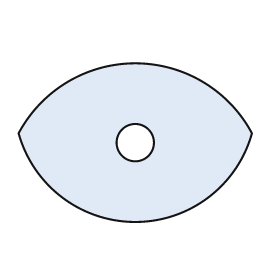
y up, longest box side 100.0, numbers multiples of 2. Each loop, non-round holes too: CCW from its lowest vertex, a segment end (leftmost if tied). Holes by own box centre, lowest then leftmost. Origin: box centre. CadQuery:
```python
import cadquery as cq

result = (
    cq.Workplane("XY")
    .moveTo(-50.0, 4.0)
    .threePointArc((0.0, -34.0), (50.0, 4.0))
    .threePointArc((0.0, 34.0), (-50.0, 4.0))
    .close()
    .moveTo(0.0, 0.0)
    .circle(8.0)
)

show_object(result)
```